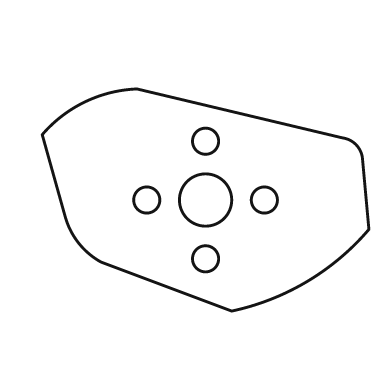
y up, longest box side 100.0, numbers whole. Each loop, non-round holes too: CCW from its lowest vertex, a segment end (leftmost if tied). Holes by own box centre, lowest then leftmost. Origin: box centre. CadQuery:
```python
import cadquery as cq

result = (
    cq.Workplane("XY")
    .moveTo(8.0, -34.0)
    .threePointArc((31.0, -25.0), (50.0, -9.0))
    .lineTo(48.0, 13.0)
    .threePointArc((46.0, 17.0), (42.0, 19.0))
    .lineTo(-21.0, 34.0)
    .threePointArc((-37.0, 30.0), (-50.0, 20.0))
    .lineTo(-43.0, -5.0)
    .threePointArc((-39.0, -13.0), (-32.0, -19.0))
    .close()
    .moveTo(0.0, -18.0)
    .circle(4.0)
    .moveTo(-18.0, 0.0)
    .circle(4.0)
    .moveTo(0.0, 0.0)
    .circle(8.0)
    .moveTo(18.0, 0.0)
    .circle(4.0)
    .moveTo(0.0, 18.0)
    .circle(4.0)
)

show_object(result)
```